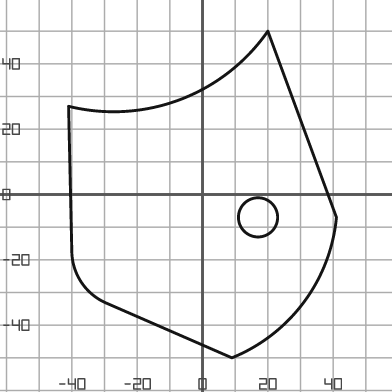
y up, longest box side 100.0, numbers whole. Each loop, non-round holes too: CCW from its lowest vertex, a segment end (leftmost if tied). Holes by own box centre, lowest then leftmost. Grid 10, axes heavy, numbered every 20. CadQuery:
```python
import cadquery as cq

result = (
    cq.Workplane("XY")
    .moveTo(9.0, -50.0)
    .threePointArc((31.0, -33.0), (41.0, -7.0))
    .lineTo(20.0, 50.0)
    .threePointArc((-7.0, 29.0), (-41.0, 27.0))
    .lineTo(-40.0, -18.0)
    .threePointArc((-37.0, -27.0), (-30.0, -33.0))
    .close()
    .moveTo(17.0, -7.0)
    .circle(6.0)
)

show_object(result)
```